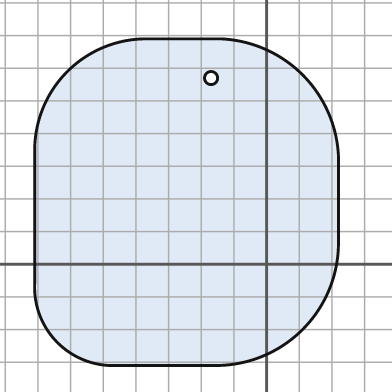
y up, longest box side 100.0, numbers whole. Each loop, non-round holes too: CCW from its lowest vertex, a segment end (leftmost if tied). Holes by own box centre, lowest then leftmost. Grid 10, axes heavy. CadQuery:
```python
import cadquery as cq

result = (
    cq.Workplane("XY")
    .moveTo(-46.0, -31.0)
    .lineTo(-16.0, -31.0)
    .threePointArc((11.0, -20.0), (22.0, 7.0))
    .lineTo(22.0, 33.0)
    .threePointArc((11.0, 58.0), (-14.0, 69.0))
    .lineTo(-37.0, 69.0)
    .threePointArc((-61.0, 59.0), (-71.0, 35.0))
    .lineTo(-71.0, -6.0)
    .threePointArc((-64.0, -24.0), (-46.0, -31.0))
    .close()
    .moveTo(-17.0, 57.0)
    .circle(2.0)
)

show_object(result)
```